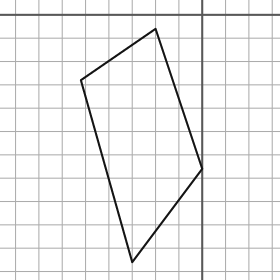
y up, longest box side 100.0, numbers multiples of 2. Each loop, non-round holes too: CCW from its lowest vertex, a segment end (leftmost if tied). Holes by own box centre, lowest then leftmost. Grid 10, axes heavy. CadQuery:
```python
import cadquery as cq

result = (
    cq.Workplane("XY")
    .moveTo(-30.0, -106.0)
    .lineTo(0.0, -66.0)
    .lineTo(-20.0, -6.0)
    .lineTo(-52.0, -28.0)
    .close()
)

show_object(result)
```